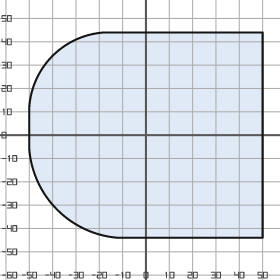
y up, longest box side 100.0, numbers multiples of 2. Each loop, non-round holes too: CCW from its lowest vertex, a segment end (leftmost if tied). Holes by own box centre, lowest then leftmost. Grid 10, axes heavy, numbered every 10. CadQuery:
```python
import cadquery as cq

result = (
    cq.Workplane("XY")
    .moveTo(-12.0, -44.0)
    .lineTo(50.0, -44.0)
    .lineTo(50.0, 44.0)
    .lineTo(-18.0, 44.0)
    .threePointArc((-40.0, 34.0), (-50.0, 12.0))
    .lineTo(-50.0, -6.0)
    .threePointArc((-38.0, -32.0), (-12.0, -44.0))
    .close()
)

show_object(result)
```